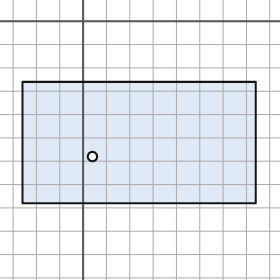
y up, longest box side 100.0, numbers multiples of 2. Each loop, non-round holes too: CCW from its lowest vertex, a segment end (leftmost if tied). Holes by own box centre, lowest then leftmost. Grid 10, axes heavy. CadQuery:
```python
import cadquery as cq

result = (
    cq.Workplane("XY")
    .moveTo(-26.0, -78.0)
    .lineTo(74.0, -78.0)
    .lineTo(74.0, -26.0)
    .lineTo(-26.0, -26.0)
    .close()
    .moveTo(4.0, -58.0)
    .circle(2.0)
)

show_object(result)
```